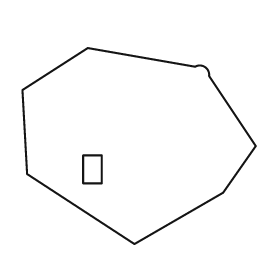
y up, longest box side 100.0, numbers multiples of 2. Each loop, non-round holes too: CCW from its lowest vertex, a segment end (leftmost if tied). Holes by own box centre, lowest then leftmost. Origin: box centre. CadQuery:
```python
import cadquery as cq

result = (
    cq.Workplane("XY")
    .moveTo(-2.0, -42.0)
    .lineTo(36.0, -20.0)
    .lineTo(50.0, 0.0)
    .lineTo(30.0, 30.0)
    .threePointArc((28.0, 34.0), (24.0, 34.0))
    .lineTo(-22.0, 42.0)
    .lineTo(-50.0, 24.0)
    .lineTo(-48.0, -12.0)
    .close()
    .moveTo(-24.0, -16.0)
    .lineTo(-16.0, -16.0)
    .lineTo(-16.0, -4.0)
    .lineTo(-24.0, -4.0)
    .close()
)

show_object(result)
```